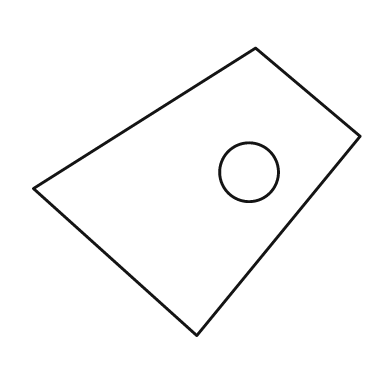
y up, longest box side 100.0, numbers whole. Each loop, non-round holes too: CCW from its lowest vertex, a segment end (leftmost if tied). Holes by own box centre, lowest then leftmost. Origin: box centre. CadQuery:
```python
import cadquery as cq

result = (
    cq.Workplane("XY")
    .moveTo(0.0, -44.0)
    .lineTo(50.0, 17.0)
    .lineTo(18.0, 44.0)
    .lineTo(-50.0, 1.0)
    .close()
    .moveTo(16.0, 6.0)
    .circle(9.0)
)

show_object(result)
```